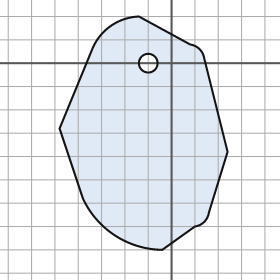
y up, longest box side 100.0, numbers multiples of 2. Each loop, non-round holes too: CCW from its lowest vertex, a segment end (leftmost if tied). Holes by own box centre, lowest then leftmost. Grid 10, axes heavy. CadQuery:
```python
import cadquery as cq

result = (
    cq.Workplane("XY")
    .moveTo(-4.0, -80.0)
    .lineTo(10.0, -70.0)
    .threePointArc((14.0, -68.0), (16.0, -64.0))
    .lineTo(24.0, -38.0)
    .lineTo(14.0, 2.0)
    .threePointArc((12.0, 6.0), (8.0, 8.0))
    .lineTo(-14.0, 20.0)
    .threePointArc((-26.0, 16.0), (-34.0, 6.0))
    .lineTo(-48.0, -28.0)
    .lineTo(-38.0, -58.0)
    .threePointArc((-24.0, -74.0), (-4.0, -80.0))
    .close()
    .moveTo(-10.0, 0.0)
    .circle(4.0)
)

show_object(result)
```